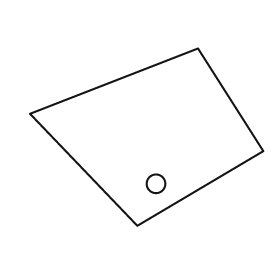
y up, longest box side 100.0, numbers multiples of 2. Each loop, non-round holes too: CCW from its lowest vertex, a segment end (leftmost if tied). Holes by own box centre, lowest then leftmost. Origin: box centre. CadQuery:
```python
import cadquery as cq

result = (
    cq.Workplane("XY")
    .moveTo(-4.0, -38.0)
    .lineTo(50.0, -6.0)
    .lineTo(22.0, 38.0)
    .lineTo(-50.0, 10.0)
    .close()
    .moveTo(4.0, -20.0)
    .circle(4.0)
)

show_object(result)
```